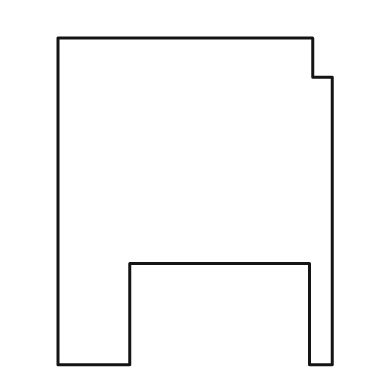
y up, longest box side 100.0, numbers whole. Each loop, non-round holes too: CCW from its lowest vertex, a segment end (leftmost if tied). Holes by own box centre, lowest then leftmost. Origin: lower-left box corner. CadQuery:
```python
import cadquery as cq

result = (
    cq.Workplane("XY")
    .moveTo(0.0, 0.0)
    .lineTo(22.0, 0.0)
    .lineTo(22.0, 31.0)
    .lineTo(77.0, 31.0)
    .lineTo(77.0, 0.0)
    .lineTo(84.0, 0.0)
    .lineTo(84.0, 88.0)
    .lineTo(78.0, 88.0)
    .lineTo(78.0, 100.0)
    .lineTo(0.0, 100.0)
    .close()
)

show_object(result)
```